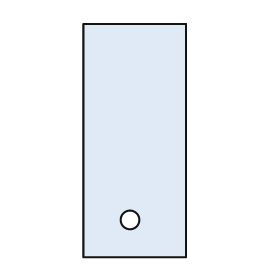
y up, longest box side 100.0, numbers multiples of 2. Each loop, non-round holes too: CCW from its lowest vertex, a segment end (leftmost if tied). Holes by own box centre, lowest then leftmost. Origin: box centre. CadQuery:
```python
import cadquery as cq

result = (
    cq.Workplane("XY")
    .moveTo(-22.0, -50.0)
    .lineTo(22.0, -50.0)
    .lineTo(22.0, 50.0)
    .lineTo(-22.0, 50.0)
    .close()
    .moveTo(-2.0, -34.0)
    .circle(4.0)
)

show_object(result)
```